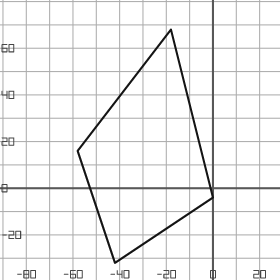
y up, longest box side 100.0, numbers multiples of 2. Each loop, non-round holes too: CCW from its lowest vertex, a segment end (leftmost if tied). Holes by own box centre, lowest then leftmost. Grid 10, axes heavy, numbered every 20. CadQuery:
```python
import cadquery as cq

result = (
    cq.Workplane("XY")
    .moveTo(-42.0, -32.0)
    .lineTo(0.0, -4.0)
    .lineTo(-18.0, 68.0)
    .lineTo(-58.0, 16.0)
    .close()
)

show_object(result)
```